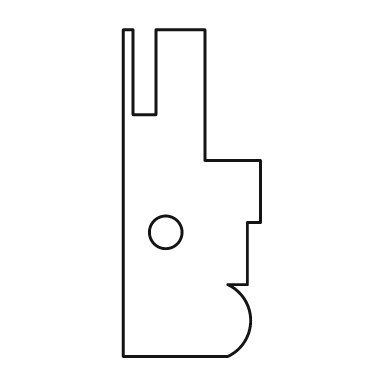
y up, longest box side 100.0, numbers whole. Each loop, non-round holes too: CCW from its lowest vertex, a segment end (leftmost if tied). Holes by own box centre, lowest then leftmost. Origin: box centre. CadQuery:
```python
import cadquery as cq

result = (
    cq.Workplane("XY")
    .moveTo(-21.0, -50.0)
    .lineTo(11.0, -50.0)
    .threePointArc((18.0, -39.0), (11.0, -28.0))
    .lineTo(17.0, -28.0)
    .lineTo(17.0, -9.0)
    .lineTo(21.0, -9.0)
    .lineTo(21.0, 10.0)
    .lineTo(4.0, 10.0)
    .lineTo(4.0, 50.0)
    .lineTo(-11.0, 50.0)
    .lineTo(-11.0, 24.0)
    .lineTo(-18.0, 24.0)
    .lineTo(-18.0, 50.0)
    .lineTo(-21.0, 50.0)
    .close()
    .moveTo(-8.0, -12.0)
    .circle(5.0)
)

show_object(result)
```